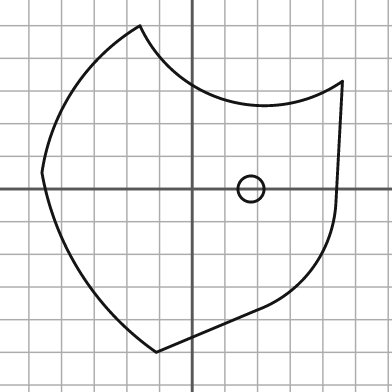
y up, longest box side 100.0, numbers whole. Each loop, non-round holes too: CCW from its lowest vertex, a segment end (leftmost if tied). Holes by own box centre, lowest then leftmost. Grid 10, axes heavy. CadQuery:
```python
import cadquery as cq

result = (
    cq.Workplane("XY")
    .moveTo(-11.0, -50.0)
    .lineTo(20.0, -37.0)
    .threePointArc((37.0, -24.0), (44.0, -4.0))
    .lineTo(46.0, 33.0)
    .threePointArc((11.0, 27.0), (-16.0, 50.0))
    .threePointArc((-36.0, 31.0), (-46.0, 5.0))
    .threePointArc((-34.0, -26.0), (-11.0, -50.0))
    .close()
    .moveTo(18.0, 0.0)
    .circle(4.0)
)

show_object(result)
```